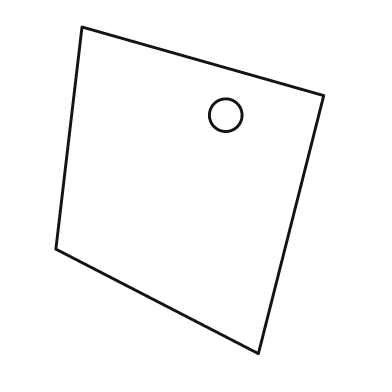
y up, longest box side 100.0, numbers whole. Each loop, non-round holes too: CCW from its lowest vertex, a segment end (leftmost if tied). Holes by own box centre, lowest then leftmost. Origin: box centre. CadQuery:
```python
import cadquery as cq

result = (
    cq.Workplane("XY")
    .moveTo(21.0, -50.0)
    .lineTo(41.0, 29.0)
    .lineTo(-33.0, 50.0)
    .lineTo(-41.0, -18.0)
    .close()
    .moveTo(11.0, 23.0)
    .circle(5.0)
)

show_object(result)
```